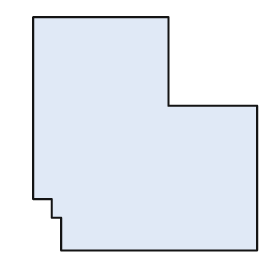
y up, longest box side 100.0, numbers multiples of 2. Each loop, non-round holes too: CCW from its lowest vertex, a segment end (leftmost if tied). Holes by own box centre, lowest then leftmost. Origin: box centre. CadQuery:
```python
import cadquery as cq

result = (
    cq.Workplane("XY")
    .moveTo(-36.0, -50.0)
    .lineTo(48.0, -50.0)
    .lineTo(48.0, 12.0)
    .lineTo(10.0, 12.0)
    .lineTo(10.0, 50.0)
    .lineTo(-48.0, 50.0)
    .lineTo(-48.0, -28.0)
    .lineTo(-40.0, -28.0)
    .lineTo(-40.0, -36.0)
    .lineTo(-36.0, -36.0)
    .close()
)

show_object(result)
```